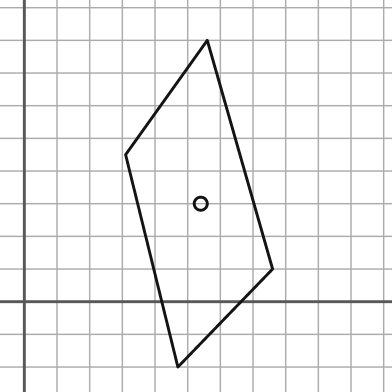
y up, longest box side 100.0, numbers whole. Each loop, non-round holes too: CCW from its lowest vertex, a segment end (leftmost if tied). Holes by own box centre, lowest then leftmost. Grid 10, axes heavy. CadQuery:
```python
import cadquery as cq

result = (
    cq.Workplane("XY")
    .moveTo(47.0, -20.0)
    .lineTo(76.0, 10.0)
    .lineTo(56.0, 80.0)
    .lineTo(31.0, 45.0)
    .close()
    .moveTo(54.0, 30.0)
    .circle(2.0)
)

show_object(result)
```